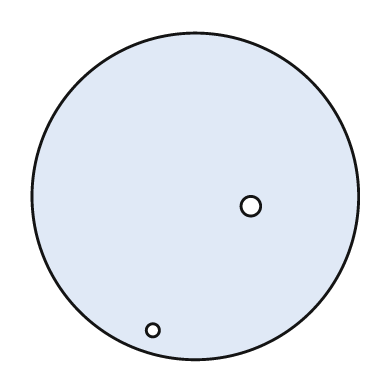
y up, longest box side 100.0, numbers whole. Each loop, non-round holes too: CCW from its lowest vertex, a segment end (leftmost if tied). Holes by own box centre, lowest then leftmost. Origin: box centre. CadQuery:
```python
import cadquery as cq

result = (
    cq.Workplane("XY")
    .moveTo(0.0, 0.0)
    .circle(50.0)
    .moveTo(-13.0, -41.0)
    .circle(2.0)
    .moveTo(17.0, -3.0)
    .circle(3.0)
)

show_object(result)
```